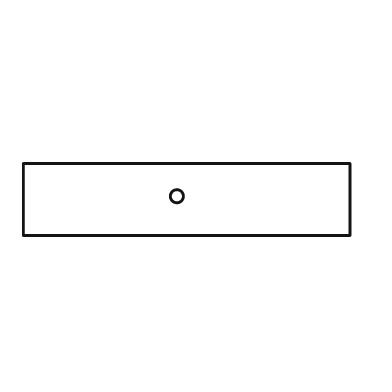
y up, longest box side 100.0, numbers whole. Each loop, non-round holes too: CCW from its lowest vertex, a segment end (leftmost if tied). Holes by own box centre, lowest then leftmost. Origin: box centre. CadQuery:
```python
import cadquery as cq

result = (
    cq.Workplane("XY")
    .moveTo(-50.0, -11.0)
    .lineTo(50.0, -11.0)
    .lineTo(50.0, 11.0)
    .lineTo(-50.0, 11.0)
    .close()
    .moveTo(-3.0, 1.0)
    .circle(2.0)
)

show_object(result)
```